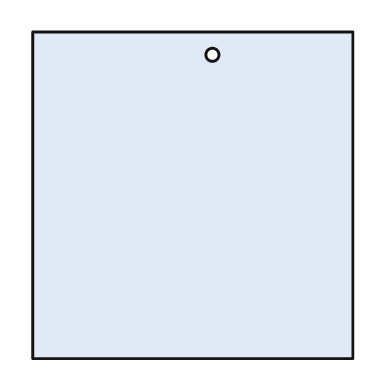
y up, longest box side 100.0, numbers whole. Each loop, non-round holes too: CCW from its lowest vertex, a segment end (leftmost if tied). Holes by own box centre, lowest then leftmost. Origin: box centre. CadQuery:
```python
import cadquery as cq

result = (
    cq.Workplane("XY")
    .moveTo(-49.0, -50.0)
    .lineTo(49.0, -50.0)
    .lineTo(49.0, 50.0)
    .lineTo(-49.0, 50.0)
    .close()
    .moveTo(6.0, 43.0)
    .circle(2.0)
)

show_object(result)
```